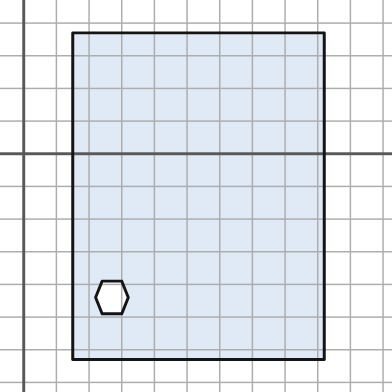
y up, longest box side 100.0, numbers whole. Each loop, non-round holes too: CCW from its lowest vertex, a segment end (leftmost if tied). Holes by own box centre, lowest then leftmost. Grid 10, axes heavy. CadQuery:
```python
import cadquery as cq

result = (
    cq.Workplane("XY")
    .moveTo(15.0, -63.0)
    .lineTo(92.0, -63.0)
    .lineTo(92.0, 37.0)
    .lineTo(15.0, 37.0)
    .close()
    .moveTo(24.0, -49.0)
    .lineTo(30.0, -49.0)
    .lineTo(32.0, -44.0)
    .lineTo(30.0, -39.0)
    .lineTo(24.0, -39.0)
    .lineTo(22.0, -44.0)
    .close()
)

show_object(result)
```